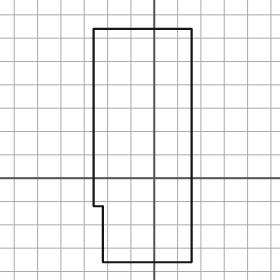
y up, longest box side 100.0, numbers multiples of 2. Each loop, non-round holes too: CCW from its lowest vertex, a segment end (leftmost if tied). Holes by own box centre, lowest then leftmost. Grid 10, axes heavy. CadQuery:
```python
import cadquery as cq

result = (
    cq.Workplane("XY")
    .moveTo(-22.0, -36.0)
    .lineTo(16.0, -36.0)
    .lineTo(16.0, 64.0)
    .lineTo(-26.0, 64.0)
    .lineTo(-26.0, -12.0)
    .lineTo(-22.0, -12.0)
    .close()
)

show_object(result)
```